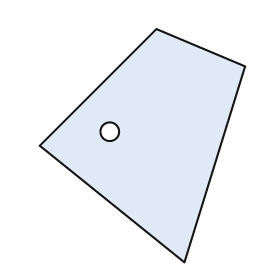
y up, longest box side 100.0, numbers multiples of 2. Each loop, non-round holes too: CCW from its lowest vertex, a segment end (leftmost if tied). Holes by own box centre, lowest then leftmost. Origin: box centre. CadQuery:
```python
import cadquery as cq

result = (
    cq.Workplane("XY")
    .moveTo(18.0, -50.0)
    .lineTo(44.0, 34.0)
    .lineTo(6.0, 50.0)
    .lineTo(-44.0, 0.0)
    .close()
    .moveTo(-14.0, 6.0)
    .circle(4.0)
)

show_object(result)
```